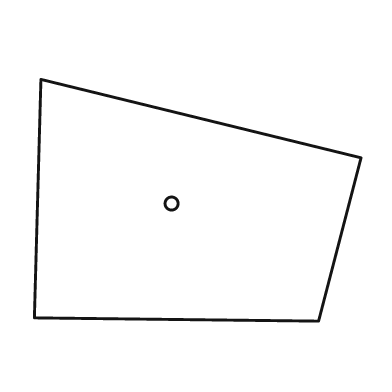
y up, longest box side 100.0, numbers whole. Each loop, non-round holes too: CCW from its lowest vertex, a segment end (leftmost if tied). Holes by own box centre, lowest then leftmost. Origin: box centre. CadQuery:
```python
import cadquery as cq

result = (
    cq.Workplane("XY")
    .moveTo(37.0, -37.0)
    .lineTo(50.0, 13.0)
    .lineTo(-48.0, 37.0)
    .lineTo(-50.0, -36.0)
    .close()
    .moveTo(-8.0, -1.0)
    .circle(2.0)
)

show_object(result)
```